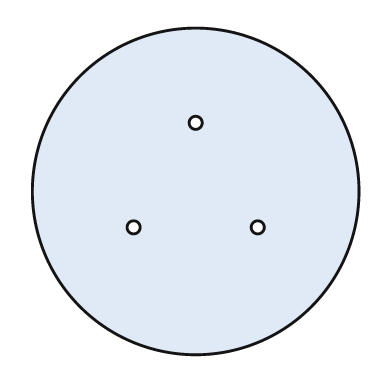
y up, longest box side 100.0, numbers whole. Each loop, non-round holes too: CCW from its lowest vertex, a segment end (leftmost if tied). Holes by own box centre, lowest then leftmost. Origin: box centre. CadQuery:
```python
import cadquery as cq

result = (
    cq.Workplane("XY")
    .moveTo(0.0, 0.0)
    .circle(50.0)
    .moveTo(-19.0, -11.0)
    .circle(2.0)
    .moveTo(19.0, -11.0)
    .circle(2.0)
    .moveTo(0.0, 21.0)
    .circle(2.0)
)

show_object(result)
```